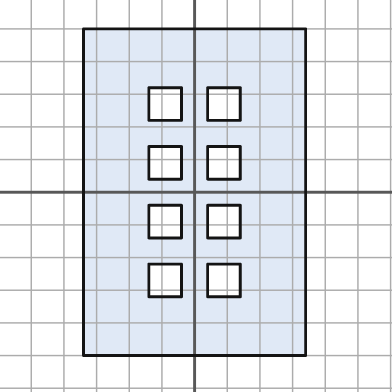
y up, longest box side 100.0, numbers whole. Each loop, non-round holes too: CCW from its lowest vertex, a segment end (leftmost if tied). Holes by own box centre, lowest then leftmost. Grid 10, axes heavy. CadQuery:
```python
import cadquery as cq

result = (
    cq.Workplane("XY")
    .moveTo(-34.0, -50.0)
    .lineTo(34.0, -50.0)
    .lineTo(34.0, 50.0)
    .lineTo(-34.0, 50.0)
    .close()
    .moveTo(-14.0, -32.0)
    .lineTo(-4.0, -32.0)
    .lineTo(-4.0, -22.0)
    .lineTo(-14.0, -22.0)
    .close()
    .moveTo(4.0, -32.0)
    .lineTo(14.0, -32.0)
    .lineTo(14.0, -22.0)
    .lineTo(4.0, -22.0)
    .close()
    .moveTo(-14.0, -14.0)
    .lineTo(-4.0, -14.0)
    .lineTo(-4.0, -4.0)
    .lineTo(-14.0, -4.0)
    .close()
    .moveTo(4.0, -14.0)
    .lineTo(14.0, -14.0)
    .lineTo(14.0, -4.0)
    .lineTo(4.0, -4.0)
    .close()
    .moveTo(-14.0, 4.0)
    .lineTo(-4.0, 4.0)
    .lineTo(-4.0, 14.0)
    .lineTo(-14.0, 14.0)
    .close()
    .moveTo(4.0, 4.0)
    .lineTo(14.0, 4.0)
    .lineTo(14.0, 14.0)
    .lineTo(4.0, 14.0)
    .close()
    .moveTo(-14.0, 22.0)
    .lineTo(-4.0, 22.0)
    .lineTo(-4.0, 32.0)
    .lineTo(-14.0, 32.0)
    .close()
    .moveTo(4.0, 22.0)
    .lineTo(14.0, 22.0)
    .lineTo(14.0, 32.0)
    .lineTo(4.0, 32.0)
    .close()
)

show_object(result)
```